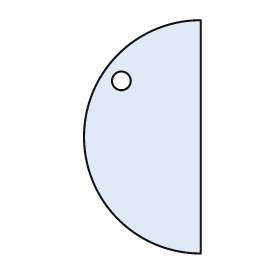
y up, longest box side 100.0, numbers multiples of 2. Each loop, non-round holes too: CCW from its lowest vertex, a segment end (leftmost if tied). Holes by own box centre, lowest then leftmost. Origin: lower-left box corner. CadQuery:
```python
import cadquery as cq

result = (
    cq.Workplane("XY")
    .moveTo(50.0, 0.0)
    .lineTo(50.0, 100.0)
    .threePointArc((0.0, 50.0), (50.0, 0.0))
    .close()
    .moveTo(16.0, 74.0)
    .circle(4.0)
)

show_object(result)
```